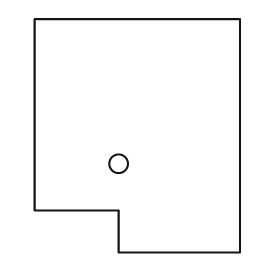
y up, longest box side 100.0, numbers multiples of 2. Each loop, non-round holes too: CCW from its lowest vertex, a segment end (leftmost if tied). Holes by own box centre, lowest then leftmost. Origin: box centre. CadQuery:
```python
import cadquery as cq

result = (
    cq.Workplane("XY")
    .moveTo(-8.0, -50.0)
    .lineTo(44.0, -50.0)
    .lineTo(44.0, 50.0)
    .lineTo(-44.0, 50.0)
    .lineTo(-44.0, -32.0)
    .lineTo(-8.0, -32.0)
    .close()
    .moveTo(-8.0, -12.0)
    .circle(4.0)
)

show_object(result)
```